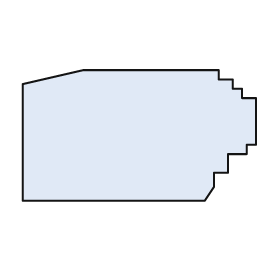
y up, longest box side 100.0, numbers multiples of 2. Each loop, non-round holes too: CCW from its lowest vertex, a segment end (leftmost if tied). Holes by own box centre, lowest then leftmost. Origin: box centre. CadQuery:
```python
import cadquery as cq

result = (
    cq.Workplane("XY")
    .moveTo(-50.0, -28.0)
    .lineTo(28.0, -28.0)
    .lineTo(32.0, -22.0)
    .lineTo(32.0, -16.0)
    .lineTo(38.0, -16.0)
    .lineTo(38.0, -8.0)
    .lineTo(46.0, -8.0)
    .lineTo(46.0, -4.0)
    .lineTo(50.0, -4.0)
    .lineTo(50.0, 16.0)
    .lineTo(44.0, 16.0)
    .lineTo(44.0, 20.0)
    .lineTo(40.0, 20.0)
    .lineTo(40.0, 24.0)
    .lineTo(34.0, 24.0)
    .lineTo(34.0, 28.0)
    .lineTo(-24.0, 28.0)
    .lineTo(-50.0, 22.0)
    .close()
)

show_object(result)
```